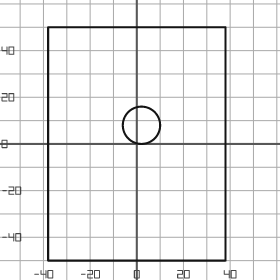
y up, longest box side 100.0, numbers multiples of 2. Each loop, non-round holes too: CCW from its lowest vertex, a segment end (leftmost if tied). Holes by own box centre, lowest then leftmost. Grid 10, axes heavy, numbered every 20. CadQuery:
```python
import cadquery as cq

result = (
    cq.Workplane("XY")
    .moveTo(-38.0, -50.0)
    .lineTo(38.0, -50.0)
    .lineTo(38.0, 50.0)
    .lineTo(-38.0, 50.0)
    .close()
    .moveTo(2.0, 8.0)
    .circle(8.0)
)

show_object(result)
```